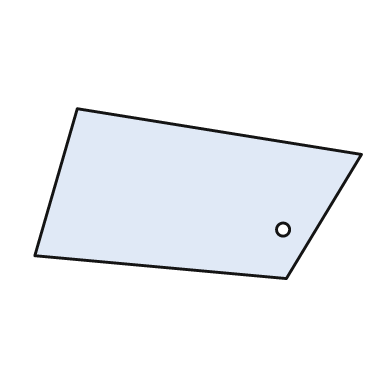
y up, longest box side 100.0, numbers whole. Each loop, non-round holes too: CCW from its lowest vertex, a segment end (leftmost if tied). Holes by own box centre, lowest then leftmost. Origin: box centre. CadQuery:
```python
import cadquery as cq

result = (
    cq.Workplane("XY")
    .moveTo(27.0, -26.0)
    .lineTo(50.0, 12.0)
    .lineTo(-37.0, 26.0)
    .lineTo(-50.0, -19.0)
    .close()
    .moveTo(26.0, -11.0)
    .circle(2.0)
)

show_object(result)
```